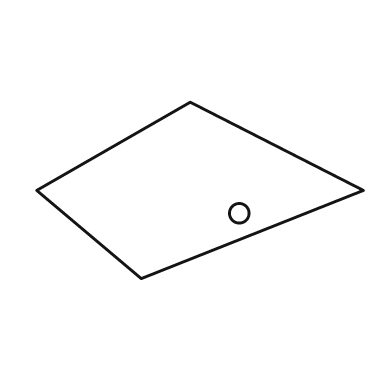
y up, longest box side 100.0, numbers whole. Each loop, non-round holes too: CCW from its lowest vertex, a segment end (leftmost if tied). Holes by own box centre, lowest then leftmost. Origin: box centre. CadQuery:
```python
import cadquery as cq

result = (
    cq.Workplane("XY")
    .moveTo(-18.0, -27.0)
    .lineTo(50.0, 0.0)
    .lineTo(-3.0, 27.0)
    .lineTo(-50.0, 0.0)
    .close()
    .moveTo(12.0, -7.0)
    .circle(3.0)
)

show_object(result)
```